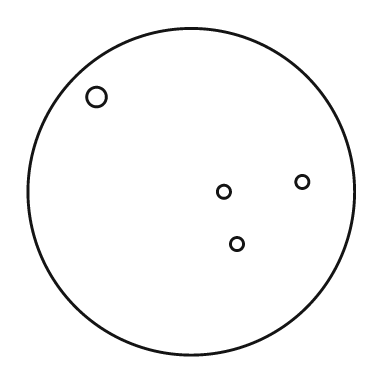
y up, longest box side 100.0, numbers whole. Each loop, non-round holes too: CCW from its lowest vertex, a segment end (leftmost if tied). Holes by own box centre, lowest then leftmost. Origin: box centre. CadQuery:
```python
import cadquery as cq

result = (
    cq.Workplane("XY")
    .moveTo(0.0, 0.0)
    .circle(50.0)
    .moveTo(14.0, -16.0)
    .circle(2.0)
    .moveTo(10.0, 0.0)
    .circle(2.0)
    .moveTo(34.0, 3.0)
    .circle(2.0)
    .moveTo(-29.0, 29.0)
    .circle(3.0)
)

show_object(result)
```